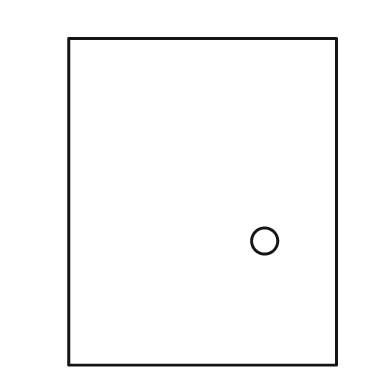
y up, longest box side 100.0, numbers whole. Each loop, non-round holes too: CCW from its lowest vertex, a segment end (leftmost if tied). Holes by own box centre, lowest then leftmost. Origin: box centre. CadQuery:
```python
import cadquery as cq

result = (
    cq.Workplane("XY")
    .moveTo(-41.0, -50.0)
    .lineTo(41.0, -50.0)
    .lineTo(41.0, 50.0)
    .lineTo(-41.0, 50.0)
    .close()
    .moveTo(19.0, -12.0)
    .circle(4.0)
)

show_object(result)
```